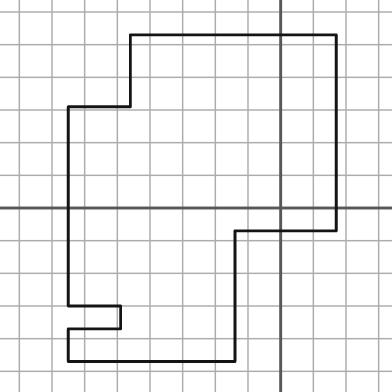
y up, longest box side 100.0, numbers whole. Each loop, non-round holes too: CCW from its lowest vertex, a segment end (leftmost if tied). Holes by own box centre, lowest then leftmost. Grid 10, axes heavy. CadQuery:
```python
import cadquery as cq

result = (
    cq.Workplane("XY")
    .moveTo(-65.0, -47.0)
    .lineTo(-14.0, -47.0)
    .lineTo(-14.0, -7.0)
    .lineTo(17.0, -7.0)
    .lineTo(17.0, 53.0)
    .lineTo(-46.0, 53.0)
    .lineTo(-46.0, 31.0)
    .lineTo(-65.0, 31.0)
    .lineTo(-65.0, -30.0)
    .lineTo(-49.0, -30.0)
    .lineTo(-49.0, -37.0)
    .lineTo(-65.0, -37.0)
    .close()
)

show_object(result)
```